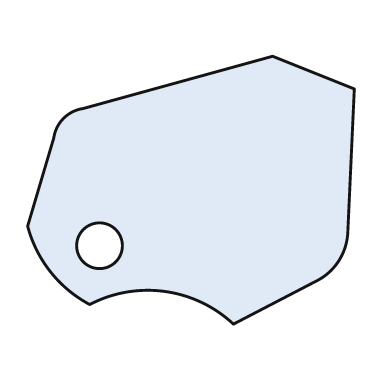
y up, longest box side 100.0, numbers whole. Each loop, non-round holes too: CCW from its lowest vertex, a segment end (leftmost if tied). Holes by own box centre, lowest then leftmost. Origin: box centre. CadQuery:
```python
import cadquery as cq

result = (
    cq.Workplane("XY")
    .moveTo(13.0, -41.0)
    .lineTo(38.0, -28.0)
    .threePointArc((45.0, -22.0), (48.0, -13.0))
    .lineTo(50.0, 31.0)
    .lineTo(25.0, 41.0)
    .lineTo(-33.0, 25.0)
    .threePointArc((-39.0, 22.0), (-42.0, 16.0))
    .lineTo(-50.0, -11.0)
    .threePointArc((-43.0, -25.0), (-31.0, -35.0))
    .threePointArc((-8.0, -31.0), (13.0, -41.0))
    .close()
    .moveTo(-28.0, -17.0)
    .circle(7.0)
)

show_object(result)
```